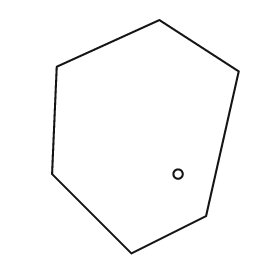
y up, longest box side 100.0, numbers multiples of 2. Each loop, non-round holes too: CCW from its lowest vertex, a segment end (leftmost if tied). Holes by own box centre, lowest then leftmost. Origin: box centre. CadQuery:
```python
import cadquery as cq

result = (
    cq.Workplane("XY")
    .moveTo(-6.0, -50.0)
    .lineTo(26.0, -34.0)
    .lineTo(40.0, 28.0)
    .lineTo(6.0, 50.0)
    .lineTo(-38.0, 30.0)
    .lineTo(-40.0, -16.0)
    .close()
    .moveTo(14.0, -16.0)
    .circle(2.0)
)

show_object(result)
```